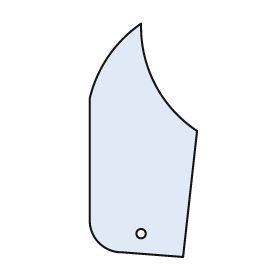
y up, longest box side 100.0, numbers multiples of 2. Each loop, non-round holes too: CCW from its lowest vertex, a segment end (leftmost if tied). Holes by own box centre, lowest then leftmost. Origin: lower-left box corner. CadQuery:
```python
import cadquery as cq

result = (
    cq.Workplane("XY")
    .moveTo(40.0, 0.0)
    .lineTo(46.0, 54.0)
    .threePointArc((28.0, 74.0), (22.0, 100.0))
    .threePointArc((8.0, 86.0), (0.0, 68.0))
    .lineTo(0.0, 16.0)
    .threePointArc((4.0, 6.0), (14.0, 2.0))
    .close()
    .moveTo(22.0, 10.0)
    .circle(2.0)
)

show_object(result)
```